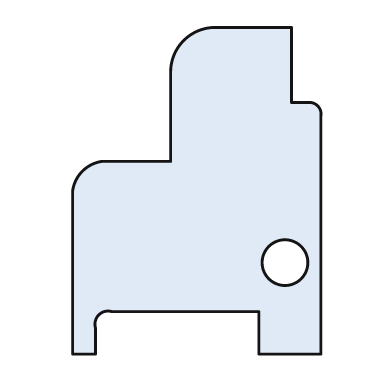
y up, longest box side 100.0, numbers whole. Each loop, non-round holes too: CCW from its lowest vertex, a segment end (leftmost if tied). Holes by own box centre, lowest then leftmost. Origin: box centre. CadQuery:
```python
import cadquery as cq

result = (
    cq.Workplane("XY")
    .moveTo(-38.0, -50.0)
    .lineTo(-31.0, -50.0)
    .lineTo(-31.0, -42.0)
    .threePointArc((-30.0, -38.0), (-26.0, -37.0))
    .lineTo(19.0, -37.0)
    .lineTo(19.0, -50.0)
    .lineTo(38.0, -50.0)
    .lineTo(38.0, 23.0)
    .threePointArc((37.0, 26.0), (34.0, 27.0))
    .lineTo(29.0, 27.0)
    .lineTo(29.0, 50.0)
    .lineTo(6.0, 50.0)
    .threePointArc((-4.0, 46.0), (-8.0, 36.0))
    .lineTo(-8.0, 9.0)
    .lineTo(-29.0, 9.0)
    .threePointArc((-35.0, 6.0), (-38.0, 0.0))
    .close()
    .moveTo(27.0, -22.0)
    .circle(7.0)
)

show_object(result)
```